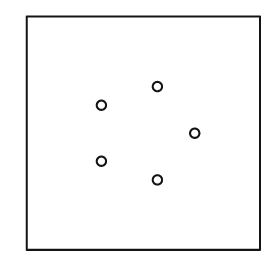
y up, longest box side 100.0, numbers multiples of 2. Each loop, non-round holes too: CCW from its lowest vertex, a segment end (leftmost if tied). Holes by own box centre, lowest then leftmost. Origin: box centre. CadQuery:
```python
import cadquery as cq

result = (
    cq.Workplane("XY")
    .moveTo(-50.0, -50.0)
    .lineTo(50.0, -50.0)
    .lineTo(50.0, 50.0)
    .lineTo(-50.0, 50.0)
    .close()
    .moveTo(6.0, -20.0)
    .circle(2.0)
    .moveTo(-18.0, -12.0)
    .circle(2.0)
    .moveTo(22.0, 0.0)
    .circle(2.0)
    .moveTo(-18.0, 12.0)
    .circle(2.0)
    .moveTo(6.0, 20.0)
    .circle(2.0)
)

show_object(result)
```